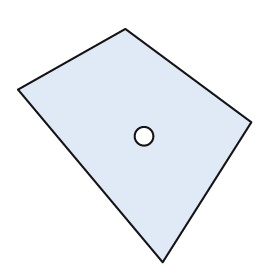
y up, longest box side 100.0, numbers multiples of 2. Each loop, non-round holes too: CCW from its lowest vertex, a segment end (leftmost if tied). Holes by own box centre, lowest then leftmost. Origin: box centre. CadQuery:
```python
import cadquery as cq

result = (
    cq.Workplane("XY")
    .moveTo(12.0, -50.0)
    .lineTo(50.0, 10.0)
    .lineTo(-4.0, 50.0)
    .lineTo(-50.0, 24.0)
    .close()
    .moveTo(4.0, 4.0)
    .circle(4.0)
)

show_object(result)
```